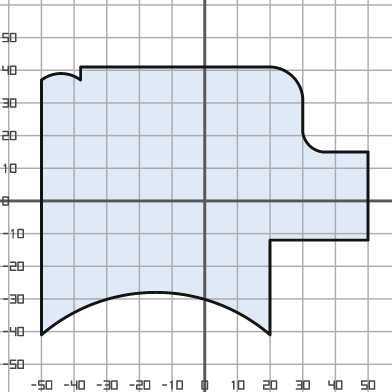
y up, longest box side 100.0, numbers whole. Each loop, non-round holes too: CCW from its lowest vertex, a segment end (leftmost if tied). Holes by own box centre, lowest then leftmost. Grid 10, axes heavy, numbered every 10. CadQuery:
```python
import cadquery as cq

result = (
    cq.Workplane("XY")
    .moveTo(-50.0, -41.0)
    .threePointArc((-15.0, -28.0), (20.0, -41.0))
    .lineTo(20.0, -12.0)
    .lineTo(50.0, -12.0)
    .lineTo(50.0, 15.0)
    .lineTo(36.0, 15.0)
    .threePointArc((32.0, 17.0), (30.0, 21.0))
    .lineTo(30.0, 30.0)
    .threePointArc((27.0, 38.0), (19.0, 41.0))
    .lineTo(-38.0, 41.0)
    .lineTo(-38.0, 37.0)
    .threePointArc((-44.0, 39.0), (-50.0, 37.0))
    .close()
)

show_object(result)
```